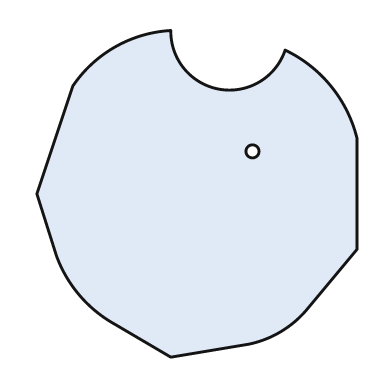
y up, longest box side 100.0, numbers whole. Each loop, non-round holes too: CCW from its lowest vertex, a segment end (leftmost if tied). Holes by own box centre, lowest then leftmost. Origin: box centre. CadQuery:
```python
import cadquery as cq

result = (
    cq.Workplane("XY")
    .moveTo(-8.0, -50.0)
    .lineTo(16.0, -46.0)
    .threePointArc((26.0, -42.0), (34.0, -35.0))
    .lineTo(49.0, -17.0)
    .lineTo(49.0, 17.0)
    .threePointArc((41.0, 33.0), (27.0, 44.0))
    .threePointArc((7.0, 32.0), (-8.0, 50.0))
    .threePointArc((-25.0, 45.0), (-38.0, 33.0))
    .lineTo(-49.0, 0.0)
    .lineTo(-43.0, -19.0)
    .threePointArc((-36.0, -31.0), (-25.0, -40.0))
    .close()
    .moveTo(17.0, 13.0)
    .circle(2.0)
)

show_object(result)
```